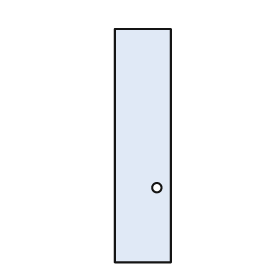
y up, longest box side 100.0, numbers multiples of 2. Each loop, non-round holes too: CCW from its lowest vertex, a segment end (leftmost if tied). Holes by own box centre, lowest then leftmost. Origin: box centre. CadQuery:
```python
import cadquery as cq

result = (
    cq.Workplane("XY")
    .moveTo(-12.0, -50.0)
    .lineTo(12.0, -50.0)
    .lineTo(12.0, 50.0)
    .lineTo(-12.0, 50.0)
    .close()
    .moveTo(6.0, -18.0)
    .circle(2.0)
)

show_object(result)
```